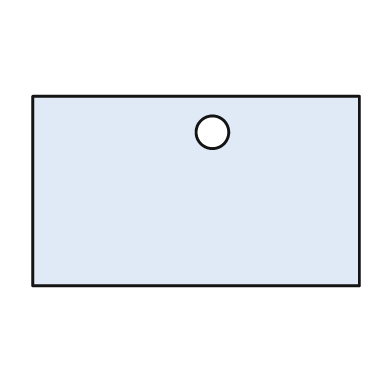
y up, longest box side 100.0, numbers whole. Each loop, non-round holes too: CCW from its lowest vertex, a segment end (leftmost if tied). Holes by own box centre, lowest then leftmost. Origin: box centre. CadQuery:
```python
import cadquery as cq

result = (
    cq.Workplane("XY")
    .moveTo(-50.0, -29.0)
    .lineTo(50.0, -29.0)
    .lineTo(50.0, 29.0)
    .lineTo(-50.0, 29.0)
    .close()
    .moveTo(5.0, 18.0)
    .circle(5.0)
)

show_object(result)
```